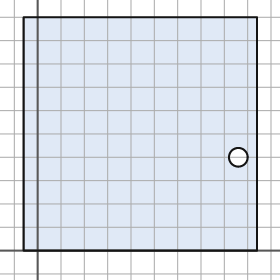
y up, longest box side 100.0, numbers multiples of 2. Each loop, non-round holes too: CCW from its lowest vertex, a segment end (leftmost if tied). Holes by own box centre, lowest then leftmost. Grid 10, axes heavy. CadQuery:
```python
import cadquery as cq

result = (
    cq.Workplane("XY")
    .moveTo(-6.0, 0.0)
    .lineTo(94.0, 0.0)
    .lineTo(94.0, 100.0)
    .lineTo(-6.0, 100.0)
    .close()
    .moveTo(86.0, 40.0)
    .circle(4.0)
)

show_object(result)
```